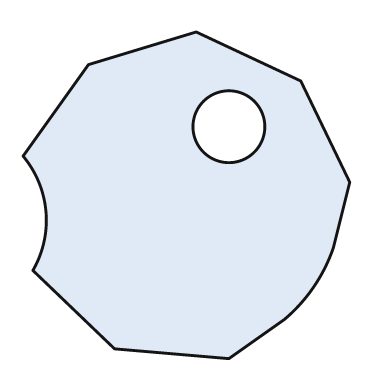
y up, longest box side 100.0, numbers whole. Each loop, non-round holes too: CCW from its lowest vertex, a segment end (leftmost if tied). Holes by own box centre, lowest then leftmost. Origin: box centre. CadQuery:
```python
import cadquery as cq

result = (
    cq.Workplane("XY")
    .moveTo(13.0, -50.0)
    .lineTo(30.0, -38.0)
    .threePointArc((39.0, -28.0), (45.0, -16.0))
    .lineTo(50.0, 4.0)
    .lineTo(35.0, 35.0)
    .lineTo(3.0, 50.0)
    .lineTo(-30.0, 40.0)
    .lineTo(-50.0, 12.0)
    .threePointArc((-43.0, -5.0), (-47.0, -23.0))
    .lineTo(-22.0, -47.0)
    .close()
    .moveTo(13.0, 21.0)
    .circle(11.0)
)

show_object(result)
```